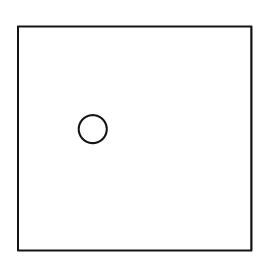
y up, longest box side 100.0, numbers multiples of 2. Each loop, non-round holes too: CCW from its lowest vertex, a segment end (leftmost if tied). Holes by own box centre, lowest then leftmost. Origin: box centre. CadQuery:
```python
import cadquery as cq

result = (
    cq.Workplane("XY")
    .moveTo(-50.0, -48.0)
    .lineTo(50.0, -48.0)
    .lineTo(50.0, 48.0)
    .lineTo(-50.0, 48.0)
    .close()
    .moveTo(-18.0, 4.0)
    .circle(6.0)
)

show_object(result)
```